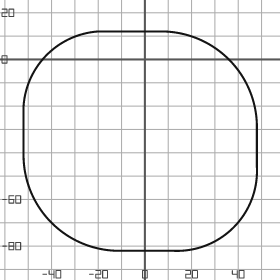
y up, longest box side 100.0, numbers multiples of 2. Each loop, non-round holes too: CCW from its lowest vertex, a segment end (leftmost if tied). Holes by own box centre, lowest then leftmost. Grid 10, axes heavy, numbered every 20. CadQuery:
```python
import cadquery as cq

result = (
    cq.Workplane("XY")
    .moveTo(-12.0, -82.0)
    .lineTo(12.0, -82.0)
    .threePointArc((38.0, -72.0), (48.0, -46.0))
    .lineTo(48.0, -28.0)
    .threePointArc((36.0, 0.0), (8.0, 12.0))
    .lineTo(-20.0, 12.0)
    .threePointArc((-42.0, 2.0), (-52.0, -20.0))
    .lineTo(-52.0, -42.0)
    .threePointArc((-40.0, -70.0), (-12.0, -82.0))
    .close()
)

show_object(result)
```